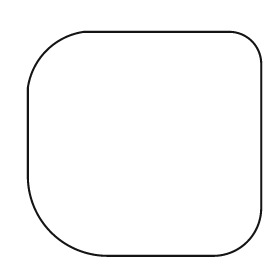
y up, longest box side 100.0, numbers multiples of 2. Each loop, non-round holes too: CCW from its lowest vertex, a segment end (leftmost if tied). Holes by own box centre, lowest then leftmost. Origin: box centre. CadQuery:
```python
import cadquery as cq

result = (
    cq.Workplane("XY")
    .moveTo(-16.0, -48.0)
    .lineTo(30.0, -48.0)
    .threePointArc((44.0, -42.0), (50.0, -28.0))
    .lineTo(50.0, 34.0)
    .threePointArc((46.0, 44.0), (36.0, 48.0))
    .lineTo(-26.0, 48.0)
    .threePointArc((-42.0, 40.0), (-50.0, 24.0))
    .lineTo(-50.0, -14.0)
    .threePointArc((-40.0, -38.0), (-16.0, -48.0))
    .close()
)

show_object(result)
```